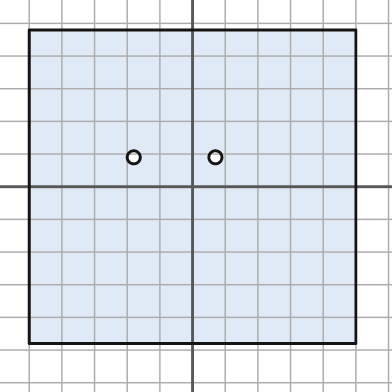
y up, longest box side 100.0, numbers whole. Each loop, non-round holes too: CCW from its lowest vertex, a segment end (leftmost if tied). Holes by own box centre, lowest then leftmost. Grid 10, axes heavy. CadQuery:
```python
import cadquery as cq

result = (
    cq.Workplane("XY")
    .moveTo(-50.0, -48.0)
    .lineTo(50.0, -48.0)
    .lineTo(50.0, 48.0)
    .lineTo(-50.0, 48.0)
    .close()
    .moveTo(-18.0, 9.0)
    .circle(2.0)
    .moveTo(7.0, 9.0)
    .circle(2.0)
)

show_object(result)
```